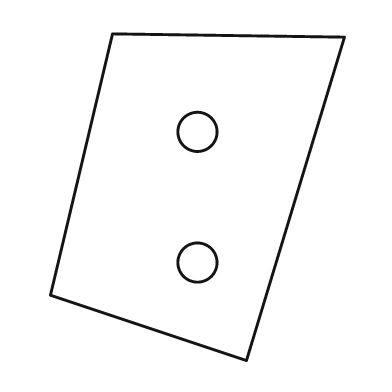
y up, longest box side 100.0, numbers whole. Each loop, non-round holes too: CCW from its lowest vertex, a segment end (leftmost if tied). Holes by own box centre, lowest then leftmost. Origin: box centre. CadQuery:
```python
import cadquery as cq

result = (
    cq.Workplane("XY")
    .moveTo(15.0, -50.0)
    .lineTo(45.0, 49.0)
    .lineTo(-26.0, 50.0)
    .lineTo(-45.0, -30.0)
    .close()
    .moveTo(0.0, -20.0)
    .circle(6.0)
    .moveTo(0.0, 20.0)
    .circle(6.0)
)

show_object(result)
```